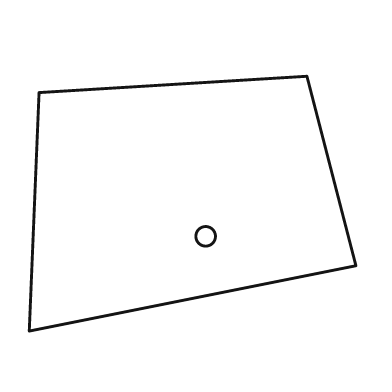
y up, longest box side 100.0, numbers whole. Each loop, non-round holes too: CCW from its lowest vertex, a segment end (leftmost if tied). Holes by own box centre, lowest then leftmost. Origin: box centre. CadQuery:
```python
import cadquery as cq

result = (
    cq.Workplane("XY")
    .moveTo(-50.0, -39.0)
    .lineTo(50.0, -19.0)
    .lineTo(35.0, 39.0)
    .lineTo(-47.0, 34.0)
    .close()
    .moveTo(4.0, -10.0)
    .circle(3.0)
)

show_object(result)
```